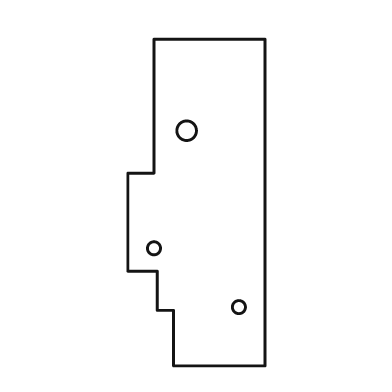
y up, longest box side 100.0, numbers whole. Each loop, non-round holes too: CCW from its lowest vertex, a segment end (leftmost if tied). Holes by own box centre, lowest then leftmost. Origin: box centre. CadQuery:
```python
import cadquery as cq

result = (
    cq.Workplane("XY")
    .moveTo(-7.0, -50.0)
    .lineTo(21.0, -50.0)
    .lineTo(21.0, 50.0)
    .lineTo(-13.0, 50.0)
    .lineTo(-13.0, 9.0)
    .lineTo(-21.0, 9.0)
    .lineTo(-21.0, -21.0)
    .lineTo(-12.0, -21.0)
    .lineTo(-12.0, -33.0)
    .lineTo(-7.0, -33.0)
    .close()
    .moveTo(13.0, -32.0)
    .circle(2.0)
    .moveTo(-13.0, -14.0)
    .circle(2.0)
    .moveTo(-3.0, 22.0)
    .circle(3.0)
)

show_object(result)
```